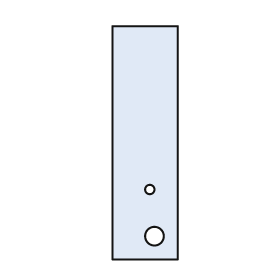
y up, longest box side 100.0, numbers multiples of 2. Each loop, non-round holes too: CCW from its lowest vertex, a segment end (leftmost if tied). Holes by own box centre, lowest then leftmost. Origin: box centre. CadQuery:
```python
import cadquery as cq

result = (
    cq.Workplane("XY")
    .moveTo(-14.0, -50.0)
    .lineTo(14.0, -50.0)
    .lineTo(14.0, 50.0)
    .lineTo(-14.0, 50.0)
    .close()
    .moveTo(4.0, -40.0)
    .circle(4.0)
    .moveTo(2.0, -20.0)
    .circle(2.0)
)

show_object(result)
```